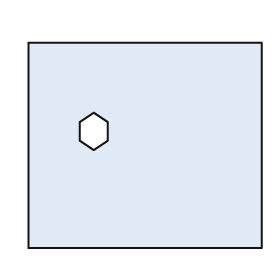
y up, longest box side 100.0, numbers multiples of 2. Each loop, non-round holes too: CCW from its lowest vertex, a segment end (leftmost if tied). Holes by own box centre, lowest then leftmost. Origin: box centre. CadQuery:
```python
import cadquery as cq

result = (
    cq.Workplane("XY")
    .moveTo(-50.0, -44.0)
    .lineTo(50.0, -44.0)
    .lineTo(50.0, 44.0)
    .lineTo(-50.0, 44.0)
    .close()
    .moveTo(-22.0, -2.0)
    .lineTo(-16.0, 2.0)
    .lineTo(-16.0, 10.0)
    .lineTo(-22.0, 14.0)
    .lineTo(-28.0, 10.0)
    .lineTo(-28.0, 2.0)
    .close()
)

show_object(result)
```